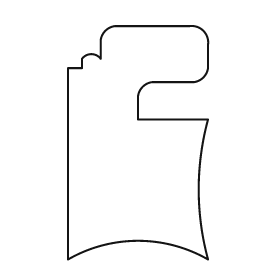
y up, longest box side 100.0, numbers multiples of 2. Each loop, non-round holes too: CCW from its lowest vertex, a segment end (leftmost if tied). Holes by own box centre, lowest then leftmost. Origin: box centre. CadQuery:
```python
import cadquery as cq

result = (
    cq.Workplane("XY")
    .moveTo(-30.0, -50.0)
    .threePointArc((0.0, -42.0), (30.0, -50.0))
    .threePointArc((26.0, -20.0), (30.0, 10.0))
    .lineTo(0.0, 10.0)
    .lineTo(0.0, 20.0)
    .threePointArc((2.0, 24.0), (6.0, 26.0))
    .lineTo(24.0, 26.0)
    .threePointArc((28.0, 28.0), (30.0, 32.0))
    .lineTo(30.0, 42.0)
    .threePointArc((28.0, 48.0), (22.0, 50.0))
    .lineTo(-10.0, 50.0)
    .threePointArc((-14.0, 48.0), (-16.0, 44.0))
    .lineTo(-16.0, 36.0)
    .threePointArc((-20.0, 38.0), (-24.0, 36.0))
    .lineTo(-24.0, 32.0)
    .lineTo(-30.0, 32.0)
    .close()
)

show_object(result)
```